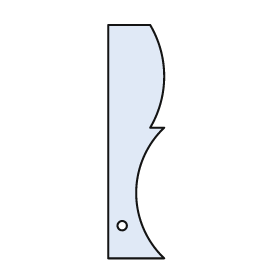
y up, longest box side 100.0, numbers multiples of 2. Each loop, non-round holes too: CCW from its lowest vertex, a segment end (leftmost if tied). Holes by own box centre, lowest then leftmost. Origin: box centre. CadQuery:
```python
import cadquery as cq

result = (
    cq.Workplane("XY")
    .moveTo(-12.0, -50.0)
    .lineTo(12.0, -50.0)
    .threePointArc((0.0, -22.0), (12.0, 6.0))
    .lineTo(6.0, 6.0)
    .threePointArc((12.0, 28.0), (6.0, 50.0))
    .lineTo(-12.0, 50.0)
    .close()
    .moveTo(-6.0, -36.0)
    .circle(2.0)
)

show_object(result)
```